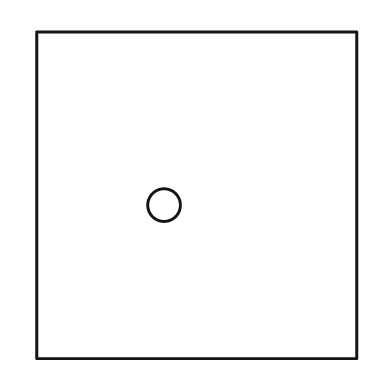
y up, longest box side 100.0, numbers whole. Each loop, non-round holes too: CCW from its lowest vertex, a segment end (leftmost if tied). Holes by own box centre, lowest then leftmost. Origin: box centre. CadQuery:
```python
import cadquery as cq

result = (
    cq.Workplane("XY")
    .moveTo(-49.0, -50.0)
    .lineTo(49.0, -50.0)
    .lineTo(49.0, 50.0)
    .lineTo(-49.0, 50.0)
    .close()
    .moveTo(-10.0, -3.0)
    .circle(5.0)
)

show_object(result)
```